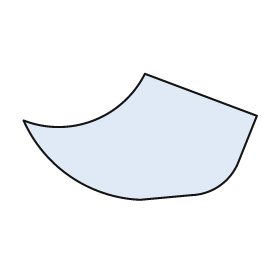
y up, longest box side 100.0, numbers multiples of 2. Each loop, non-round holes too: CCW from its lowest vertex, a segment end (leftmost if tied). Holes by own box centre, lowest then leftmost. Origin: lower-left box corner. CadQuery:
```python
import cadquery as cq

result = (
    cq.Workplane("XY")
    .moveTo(50.0, 0.0)
    .lineTo(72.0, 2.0)
    .threePointArc((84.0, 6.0), (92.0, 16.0))
    .lineTo(100.0, 36.0)
    .lineTo(52.0, 54.0)
    .threePointArc((30.0, 34.0), (0.0, 34.0))
    .threePointArc((20.0, 10.0), (50.0, 0.0))
    .close()
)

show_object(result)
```